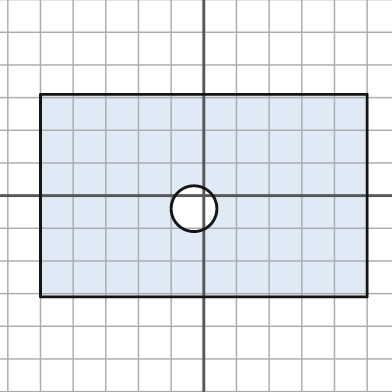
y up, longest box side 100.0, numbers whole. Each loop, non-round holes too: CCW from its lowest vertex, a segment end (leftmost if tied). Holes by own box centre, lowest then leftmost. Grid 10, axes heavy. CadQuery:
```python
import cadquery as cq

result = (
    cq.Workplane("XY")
    .moveTo(-50.0, -31.0)
    .lineTo(50.0, -31.0)
    .lineTo(50.0, 31.0)
    .lineTo(-50.0, 31.0)
    .close()
    .moveTo(-3.0, -4.0)
    .circle(7.0)
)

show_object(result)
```